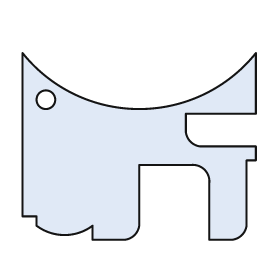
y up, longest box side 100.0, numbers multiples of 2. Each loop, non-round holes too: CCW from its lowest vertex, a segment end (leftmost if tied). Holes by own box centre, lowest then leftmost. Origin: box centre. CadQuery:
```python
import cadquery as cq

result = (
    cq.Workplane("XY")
    .moveTo(-20.0, -40.0)
    .lineTo(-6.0, -40.0)
    .threePointArc((-2.0, -38.0), (0.0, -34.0))
    .lineTo(0.0, -8.0)
    .lineTo(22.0, -8.0)
    .threePointArc((28.0, -10.0), (30.0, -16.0))
    .lineTo(30.0, -40.0)
    .lineTo(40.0, -40.0)
    .threePointArc((44.0, -38.0), (46.0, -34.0))
    .lineTo(46.0, -6.0)
    .lineTo(50.0, -6.0)
    .lineTo(50.0, 0.0)
    .lineTo(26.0, 0.0)
    .threePointArc((22.0, 2.0), (20.0, 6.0))
    .lineTo(20.0, 14.0)
    .lineTo(50.0, 14.0)
    .lineTo(50.0, 40.0)
    .threePointArc((0.0, 16.0), (-50.0, 40.0))
    .lineTo(-50.0, -30.0)
    .lineTo(-44.0, -30.0)
    .lineTo(-44.0, -34.0)
    .threePointArc((-32.0, -38.0), (-20.0, -34.0))
    .close()
    .moveTo(-40.0, 20.0)
    .circle(4.0)
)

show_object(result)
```